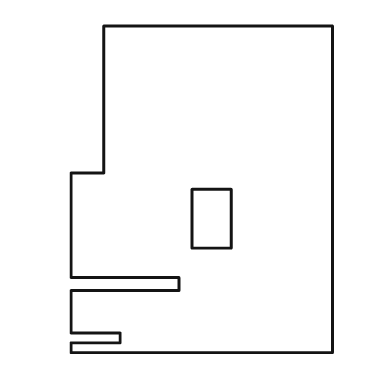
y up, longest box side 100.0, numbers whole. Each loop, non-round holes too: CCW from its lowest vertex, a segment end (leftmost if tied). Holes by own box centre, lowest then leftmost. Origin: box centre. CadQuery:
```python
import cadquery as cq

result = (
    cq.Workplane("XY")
    .moveTo(-40.0, -50.0)
    .lineTo(40.0, -50.0)
    .lineTo(40.0, 50.0)
    .lineTo(-30.0, 50.0)
    .lineTo(-30.0, 5.0)
    .lineTo(-40.0, 5.0)
    .lineTo(-40.0, -27.0)
    .lineTo(-7.0, -27.0)
    .lineTo(-7.0, -31.0)
    .lineTo(-40.0, -31.0)
    .lineTo(-40.0, -44.0)
    .lineTo(-25.0, -44.0)
    .lineTo(-25.0, -47.0)
    .lineTo(-40.0, -47.0)
    .close()
    .moveTo(-3.0, -18.0)
    .lineTo(9.0, -18.0)
    .lineTo(9.0, 0.0)
    .lineTo(-3.0, 0.0)
    .close()
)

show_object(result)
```